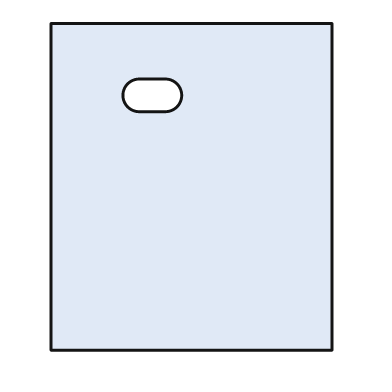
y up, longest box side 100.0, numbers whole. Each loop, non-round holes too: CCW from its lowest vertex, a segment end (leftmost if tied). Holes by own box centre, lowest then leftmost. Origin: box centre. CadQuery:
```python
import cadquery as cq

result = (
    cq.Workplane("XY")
    .moveTo(-43.0, -50.0)
    .lineTo(43.0, -50.0)
    .lineTo(43.0, 50.0)
    .lineTo(-43.0, 50.0)
    .close()
    .moveTo(-16.0, 23.0)
    .lineTo(-8.0, 23.0)
    .threePointArc((-3.0, 28.0), (-8.0, 33.0))
    .lineTo(-16.0, 33.0)
    .threePointArc((-21.0, 28.0), (-16.0, 23.0))
    .close()
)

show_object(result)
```